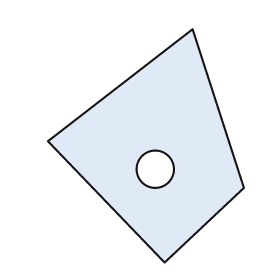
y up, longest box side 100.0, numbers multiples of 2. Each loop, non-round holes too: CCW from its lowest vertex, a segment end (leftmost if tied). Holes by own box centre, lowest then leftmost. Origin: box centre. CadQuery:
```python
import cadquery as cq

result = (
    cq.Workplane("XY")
    .moveTo(8.0, -50.0)
    .lineTo(42.0, -18.0)
    .lineTo(20.0, 50.0)
    .lineTo(-42.0, 2.0)
    .close()
    .moveTo(4.0, -10.0)
    .circle(8.0)
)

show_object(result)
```